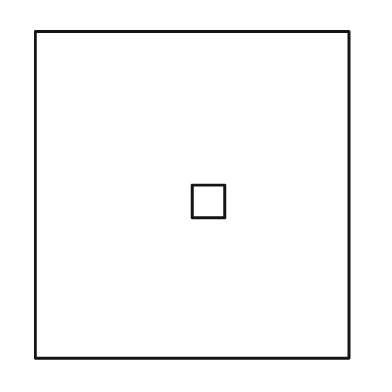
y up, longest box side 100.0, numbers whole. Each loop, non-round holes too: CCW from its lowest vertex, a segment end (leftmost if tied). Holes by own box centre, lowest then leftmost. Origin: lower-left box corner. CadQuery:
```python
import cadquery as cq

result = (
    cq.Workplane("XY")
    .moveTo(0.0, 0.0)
    .lineTo(96.0, 0.0)
    .lineTo(96.0, 100.0)
    .lineTo(0.0, 100.0)
    .close()
    .moveTo(48.0, 43.0)
    .lineTo(58.0, 43.0)
    .lineTo(58.0, 53.0)
    .lineTo(48.0, 53.0)
    .close()
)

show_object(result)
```